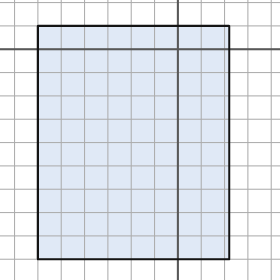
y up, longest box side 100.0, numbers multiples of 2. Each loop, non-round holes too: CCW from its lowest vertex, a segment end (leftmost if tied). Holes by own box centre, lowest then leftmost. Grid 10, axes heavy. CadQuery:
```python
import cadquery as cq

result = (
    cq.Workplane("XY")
    .moveTo(-60.0, -90.0)
    .lineTo(22.0, -90.0)
    .lineTo(22.0, 10.0)
    .lineTo(-60.0, 10.0)
    .close()
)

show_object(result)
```